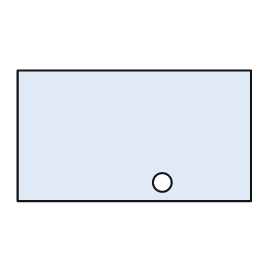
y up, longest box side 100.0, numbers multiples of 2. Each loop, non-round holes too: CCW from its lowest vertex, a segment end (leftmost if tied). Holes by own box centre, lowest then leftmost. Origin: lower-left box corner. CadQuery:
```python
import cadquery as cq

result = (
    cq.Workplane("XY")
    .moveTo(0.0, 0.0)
    .lineTo(100.0, 0.0)
    .lineTo(100.0, 56.0)
    .lineTo(0.0, 56.0)
    .close()
    .moveTo(62.0, 8.0)
    .circle(4.0)
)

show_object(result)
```